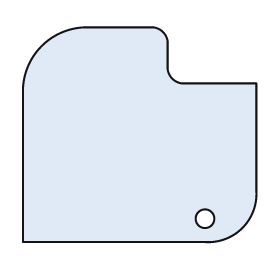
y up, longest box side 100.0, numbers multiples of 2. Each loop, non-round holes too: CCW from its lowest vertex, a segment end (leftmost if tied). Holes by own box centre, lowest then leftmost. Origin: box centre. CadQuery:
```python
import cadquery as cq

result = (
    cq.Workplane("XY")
    .moveTo(-50.0, -46.0)
    .lineTo(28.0, -46.0)
    .threePointArc((44.0, -40.0), (50.0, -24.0))
    .lineTo(50.0, 22.0)
    .lineTo(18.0, 22.0)
    .threePointArc((14.0, 24.0), (12.0, 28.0))
    .lineTo(12.0, 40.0)
    .threePointArc((10.0, 44.0), (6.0, 46.0))
    .lineTo(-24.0, 46.0)
    .threePointArc((-42.0, 38.0), (-50.0, 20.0))
    .close()
    .moveTo(28.0, -36.0)
    .circle(4.0)
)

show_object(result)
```